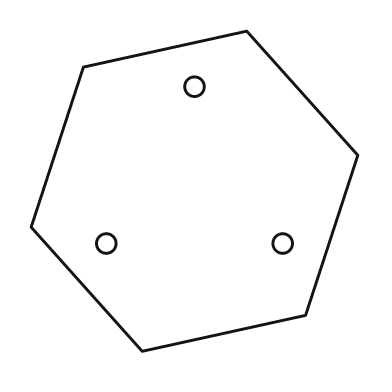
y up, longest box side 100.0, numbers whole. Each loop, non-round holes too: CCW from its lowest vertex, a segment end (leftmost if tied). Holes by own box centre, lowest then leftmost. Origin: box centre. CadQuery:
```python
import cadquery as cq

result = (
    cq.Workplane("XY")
    .moveTo(-16.0, -49.0)
    .lineTo(34.0, -38.0)
    .lineTo(50.0, 11.0)
    .lineTo(16.0, 49.0)
    .lineTo(-34.0, 38.0)
    .lineTo(-50.0, -11.0)
    .close()
    .moveTo(-27.0, -16.0)
    .circle(3.0)
    .moveTo(27.0, -16.0)
    .circle(3.0)
    .moveTo(0.0, 32.0)
    .circle(3.0)
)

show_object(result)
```